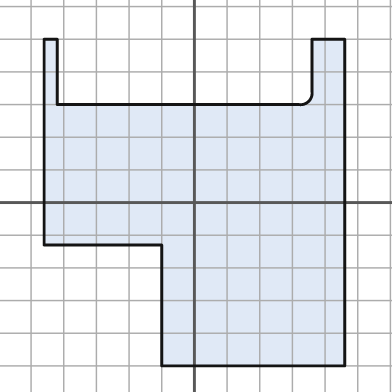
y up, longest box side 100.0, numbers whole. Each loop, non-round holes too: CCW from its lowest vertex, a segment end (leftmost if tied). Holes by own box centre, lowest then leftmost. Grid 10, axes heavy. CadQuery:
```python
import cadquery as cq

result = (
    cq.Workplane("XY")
    .moveTo(-10.0, -50.0)
    .lineTo(46.0, -50.0)
    .lineTo(46.0, 50.0)
    .lineTo(36.0, 50.0)
    .lineTo(36.0, 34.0)
    .threePointArc((35.0, 31.0), (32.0, 30.0))
    .lineTo(-42.0, 30.0)
    .lineTo(-42.0, 50.0)
    .lineTo(-46.0, 50.0)
    .lineTo(-46.0, -13.0)
    .lineTo(-10.0, -13.0)
    .close()
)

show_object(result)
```